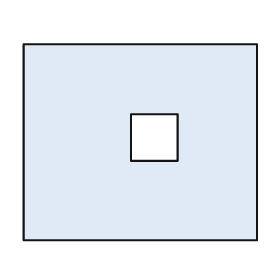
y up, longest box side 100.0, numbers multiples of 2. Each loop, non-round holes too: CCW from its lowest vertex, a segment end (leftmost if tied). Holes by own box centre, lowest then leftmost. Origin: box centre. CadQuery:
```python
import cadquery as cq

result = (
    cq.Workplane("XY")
    .moveTo(-50.0, -42.0)
    .lineTo(50.0, -42.0)
    .lineTo(50.0, 42.0)
    .lineTo(-50.0, 42.0)
    .close()
    .moveTo(-4.0, -8.0)
    .lineTo(16.0, -8.0)
    .lineTo(16.0, 12.0)
    .lineTo(-4.0, 12.0)
    .close()
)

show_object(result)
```